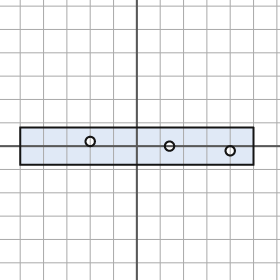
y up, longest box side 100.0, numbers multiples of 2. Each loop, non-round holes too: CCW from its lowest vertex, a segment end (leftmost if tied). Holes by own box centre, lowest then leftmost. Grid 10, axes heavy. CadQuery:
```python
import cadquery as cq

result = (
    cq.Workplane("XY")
    .moveTo(-50.0, -8.0)
    .lineTo(50.0, -8.0)
    .lineTo(50.0, 8.0)
    .lineTo(-50.0, 8.0)
    .close()
    .moveTo(40.0, -2.0)
    .circle(2.0)
    .moveTo(14.0, 0.0)
    .circle(2.0)
    .moveTo(-20.0, 2.0)
    .circle(2.0)
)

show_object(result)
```